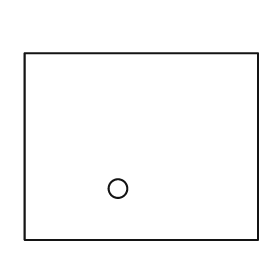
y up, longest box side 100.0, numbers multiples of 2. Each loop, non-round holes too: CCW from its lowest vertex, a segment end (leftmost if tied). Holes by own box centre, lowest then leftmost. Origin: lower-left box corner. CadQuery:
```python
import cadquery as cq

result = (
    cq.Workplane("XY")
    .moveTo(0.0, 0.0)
    .lineTo(100.0, 0.0)
    .lineTo(100.0, 80.0)
    .lineTo(0.0, 80.0)
    .close()
    .moveTo(40.0, 22.0)
    .circle(4.0)
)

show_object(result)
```